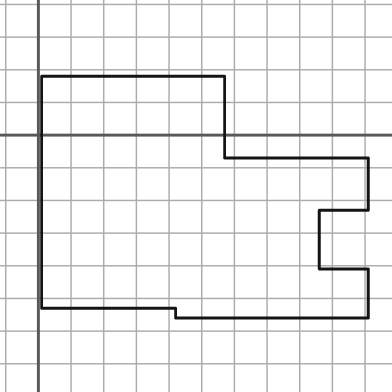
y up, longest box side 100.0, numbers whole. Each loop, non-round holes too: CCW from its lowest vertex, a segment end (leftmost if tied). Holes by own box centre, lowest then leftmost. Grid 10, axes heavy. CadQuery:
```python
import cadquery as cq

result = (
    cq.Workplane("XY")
    .moveTo(42.0, -56.0)
    .lineTo(101.0, -56.0)
    .lineTo(101.0, -41.0)
    .lineTo(86.0, -41.0)
    .lineTo(86.0, -23.0)
    .lineTo(101.0, -23.0)
    .lineTo(101.0, -7.0)
    .lineTo(57.0, -7.0)
    .lineTo(57.0, 18.0)
    .lineTo(1.0, 18.0)
    .lineTo(1.0, -53.0)
    .lineTo(42.0, -53.0)
    .close()
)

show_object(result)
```